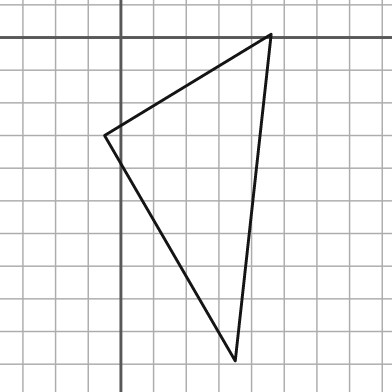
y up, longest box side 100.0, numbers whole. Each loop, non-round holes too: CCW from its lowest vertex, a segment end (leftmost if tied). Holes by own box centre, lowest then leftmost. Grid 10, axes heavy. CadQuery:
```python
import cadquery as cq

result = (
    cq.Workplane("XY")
    .moveTo(35.0, -99.0)
    .lineTo(46.0, 1.0)
    .lineTo(-5.0, -30.0)
    .close()
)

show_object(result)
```